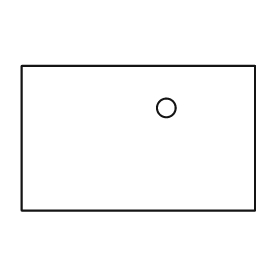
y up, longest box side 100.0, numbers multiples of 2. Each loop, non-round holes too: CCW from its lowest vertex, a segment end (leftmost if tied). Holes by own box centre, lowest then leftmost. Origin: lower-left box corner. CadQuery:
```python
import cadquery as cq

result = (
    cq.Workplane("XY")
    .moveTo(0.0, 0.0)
    .lineTo(100.0, 0.0)
    .lineTo(100.0, 62.0)
    .lineTo(0.0, 62.0)
    .close()
    .moveTo(62.0, 44.0)
    .circle(4.0)
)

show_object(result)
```